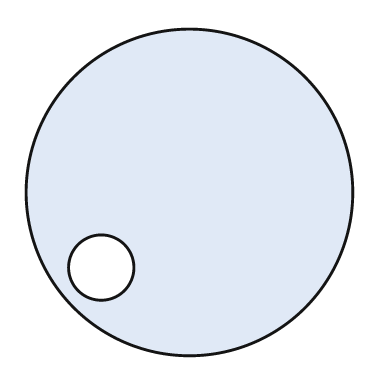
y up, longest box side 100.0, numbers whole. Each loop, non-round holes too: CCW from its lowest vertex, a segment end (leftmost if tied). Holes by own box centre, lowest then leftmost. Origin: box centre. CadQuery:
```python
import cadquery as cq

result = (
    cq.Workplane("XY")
    .moveTo(0.0, 0.0)
    .circle(50.0)
    .moveTo(-27.0, -23.0)
    .circle(10.0)
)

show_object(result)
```